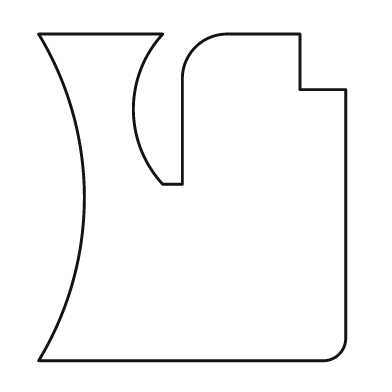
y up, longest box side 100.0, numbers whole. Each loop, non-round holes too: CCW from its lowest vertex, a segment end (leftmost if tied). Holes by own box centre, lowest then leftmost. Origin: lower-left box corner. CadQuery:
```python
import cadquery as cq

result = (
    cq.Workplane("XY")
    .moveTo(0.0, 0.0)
    .lineTo(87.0, 0.0)
    .threePointArc((92.0, 2.0), (94.0, 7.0))
    .lineTo(94.0, 83.0)
    .lineTo(80.0, 83.0)
    .lineTo(80.0, 100.0)
    .lineTo(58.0, 100.0)
    .threePointArc((48.0, 96.0), (44.0, 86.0))
    .lineTo(44.0, 54.0)
    .lineTo(38.0, 54.0)
    .threePointArc((29.0, 77.0), (38.0, 100.0))
    .lineTo(0.0, 100.0)
    .threePointArc((14.0, 50.0), (0.0, 0.0))
    .close()
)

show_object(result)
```